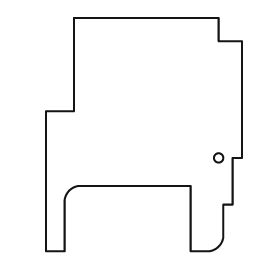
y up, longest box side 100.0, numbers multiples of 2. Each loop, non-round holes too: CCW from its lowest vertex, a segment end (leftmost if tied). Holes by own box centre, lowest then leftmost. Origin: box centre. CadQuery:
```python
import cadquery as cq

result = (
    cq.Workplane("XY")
    .moveTo(-42.0, -50.0)
    .lineTo(-34.0, -50.0)
    .lineTo(-34.0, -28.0)
    .threePointArc((-32.0, -24.0), (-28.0, -22.0))
    .lineTo(20.0, -22.0)
    .lineTo(20.0, -50.0)
    .lineTo(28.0, -50.0)
    .threePointArc((32.0, -48.0), (34.0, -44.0))
    .lineTo(34.0, -30.0)
    .lineTo(38.0, -30.0)
    .lineTo(38.0, -10.0)
    .lineTo(42.0, -10.0)
    .lineTo(42.0, 40.0)
    .lineTo(32.0, 40.0)
    .lineTo(32.0, 50.0)
    .lineTo(-30.0, 50.0)
    .lineTo(-30.0, 10.0)
    .lineTo(-42.0, 10.0)
    .close()
    .moveTo(32.0, -10.0)
    .circle(2.0)
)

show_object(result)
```